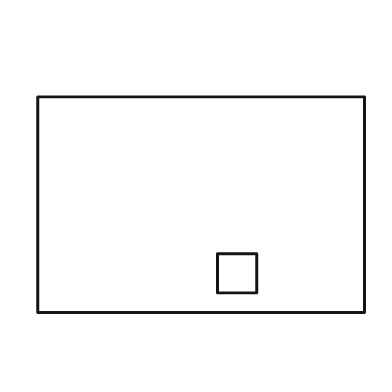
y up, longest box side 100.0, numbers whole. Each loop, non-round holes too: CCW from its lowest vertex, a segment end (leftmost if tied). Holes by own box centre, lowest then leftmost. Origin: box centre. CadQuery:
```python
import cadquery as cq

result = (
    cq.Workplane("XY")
    .moveTo(-50.0, -33.0)
    .lineTo(50.0, -33.0)
    .lineTo(50.0, 33.0)
    .lineTo(-50.0, 33.0)
    .close()
    .moveTo(5.0, -27.0)
    .lineTo(17.0, -27.0)
    .lineTo(17.0, -15.0)
    .lineTo(5.0, -15.0)
    .close()
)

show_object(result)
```